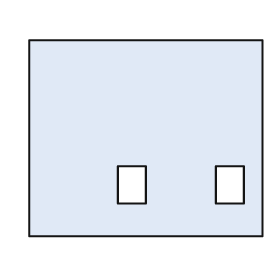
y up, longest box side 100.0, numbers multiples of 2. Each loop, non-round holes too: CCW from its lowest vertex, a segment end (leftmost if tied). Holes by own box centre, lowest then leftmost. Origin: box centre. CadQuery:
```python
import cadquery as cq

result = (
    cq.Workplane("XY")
    .moveTo(-50.0, -42.0)
    .lineTo(50.0, -42.0)
    .lineTo(50.0, 42.0)
    .lineTo(-50.0, 42.0)
    .close()
    .moveTo(-12.0, -28.0)
    .lineTo(0.0, -28.0)
    .lineTo(0.0, -12.0)
    .lineTo(-12.0, -12.0)
    .close()
    .moveTo(30.0, -28.0)
    .lineTo(42.0, -28.0)
    .lineTo(42.0, -12.0)
    .lineTo(30.0, -12.0)
    .close()
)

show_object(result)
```